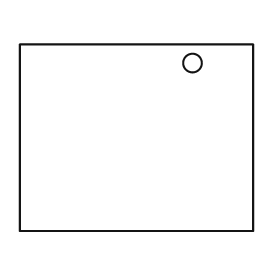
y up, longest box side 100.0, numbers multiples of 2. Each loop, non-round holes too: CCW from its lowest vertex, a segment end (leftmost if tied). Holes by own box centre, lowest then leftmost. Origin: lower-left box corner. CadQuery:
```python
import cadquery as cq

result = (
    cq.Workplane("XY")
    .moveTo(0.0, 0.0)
    .lineTo(100.0, 0.0)
    .lineTo(100.0, 80.0)
    .lineTo(0.0, 80.0)
    .close()
    .moveTo(74.0, 72.0)
    .circle(4.0)
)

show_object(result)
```